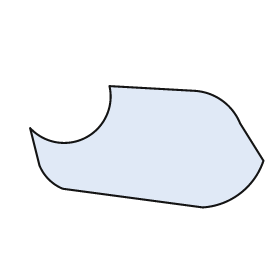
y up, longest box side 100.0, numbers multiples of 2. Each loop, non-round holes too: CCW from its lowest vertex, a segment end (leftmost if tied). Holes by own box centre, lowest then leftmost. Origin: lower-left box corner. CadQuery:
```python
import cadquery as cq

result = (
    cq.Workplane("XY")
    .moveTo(74.0, 0.0)
    .threePointArc((90.0, 6.0), (100.0, 20.0))
    .lineTo(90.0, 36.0)
    .threePointArc((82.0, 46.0), (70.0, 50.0))
    .lineTo(34.0, 52.0)
    .threePointArc((24.0, 30.0), (0.0, 34.0))
    .lineTo(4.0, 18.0)
    .threePointArc((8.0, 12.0), (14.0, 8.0))
    .close()
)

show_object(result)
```